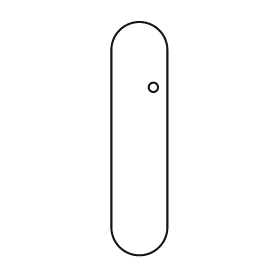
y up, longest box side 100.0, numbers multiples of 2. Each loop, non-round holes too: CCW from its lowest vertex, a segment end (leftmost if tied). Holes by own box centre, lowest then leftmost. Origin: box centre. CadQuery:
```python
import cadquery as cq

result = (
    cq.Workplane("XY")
    .moveTo(-12.0, -38.0)
    .threePointArc((0.0, -50.0), (12.0, -38.0))
    .lineTo(12.0, 38.0)
    .threePointArc((0.0, 50.0), (-12.0, 38.0))
    .close()
    .moveTo(6.0, 22.0)
    .circle(2.0)
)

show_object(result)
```